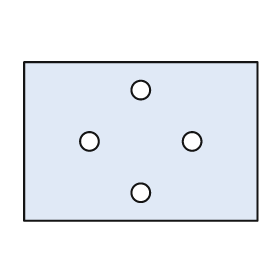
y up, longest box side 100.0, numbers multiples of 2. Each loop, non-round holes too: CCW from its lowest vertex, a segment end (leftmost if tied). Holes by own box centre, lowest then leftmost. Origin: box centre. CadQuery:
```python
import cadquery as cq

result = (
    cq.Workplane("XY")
    .moveTo(-50.0, -34.0)
    .lineTo(50.0, -34.0)
    .lineTo(50.0, 34.0)
    .lineTo(-50.0, 34.0)
    .close()
    .moveTo(0.0, -22.0)
    .circle(4.0)
    .moveTo(-22.0, 0.0)
    .circle(4.0)
    .moveTo(22.0, 0.0)
    .circle(4.0)
    .moveTo(0.0, 22.0)
    .circle(4.0)
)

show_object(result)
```